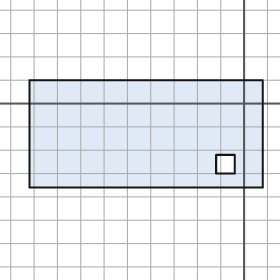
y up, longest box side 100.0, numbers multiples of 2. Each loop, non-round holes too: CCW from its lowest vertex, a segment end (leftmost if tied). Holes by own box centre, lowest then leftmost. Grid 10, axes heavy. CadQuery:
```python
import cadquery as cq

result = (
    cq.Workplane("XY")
    .moveTo(-92.0, -36.0)
    .lineTo(8.0, -36.0)
    .lineTo(8.0, 10.0)
    .lineTo(-92.0, 10.0)
    .close()
    .moveTo(-12.0, -30.0)
    .lineTo(-4.0, -30.0)
    .lineTo(-4.0, -22.0)
    .lineTo(-12.0, -22.0)
    .close()
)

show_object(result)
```